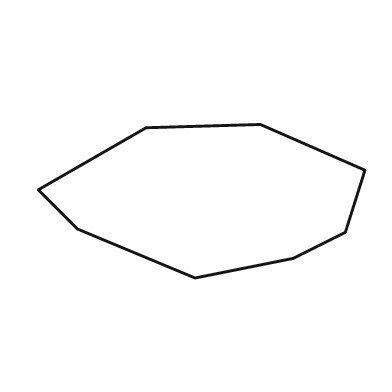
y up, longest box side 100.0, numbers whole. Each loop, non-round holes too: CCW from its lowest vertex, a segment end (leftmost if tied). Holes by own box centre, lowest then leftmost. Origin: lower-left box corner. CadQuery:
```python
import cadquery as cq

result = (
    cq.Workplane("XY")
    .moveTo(48.0, 0.0)
    .lineTo(78.0, 6.0)
    .lineTo(94.0, 14.0)
    .lineTo(100.0, 33.0)
    .lineTo(68.0, 47.0)
    .lineTo(33.0, 46.0)
    .lineTo(0.0, 27.0)
    .lineTo(12.0, 15.0)
    .close()
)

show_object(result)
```